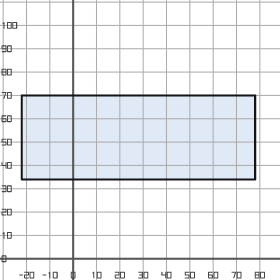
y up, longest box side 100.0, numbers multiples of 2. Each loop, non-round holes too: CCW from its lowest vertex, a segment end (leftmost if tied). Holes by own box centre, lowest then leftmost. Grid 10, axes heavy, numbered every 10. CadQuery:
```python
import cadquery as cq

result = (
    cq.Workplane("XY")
    .moveTo(-22.0, 34.0)
    .lineTo(78.0, 34.0)
    .lineTo(78.0, 70.0)
    .lineTo(-22.0, 70.0)
    .close()
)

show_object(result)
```